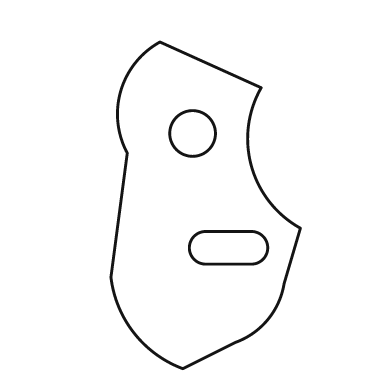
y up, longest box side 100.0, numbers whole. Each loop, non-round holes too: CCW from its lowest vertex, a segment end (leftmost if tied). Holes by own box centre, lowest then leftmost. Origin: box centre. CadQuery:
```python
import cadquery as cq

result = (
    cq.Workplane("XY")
    .moveTo(-7.0, -50.0)
    .lineTo(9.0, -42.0)
    .threePointArc((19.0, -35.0), (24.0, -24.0))
    .lineTo(29.0, -7.0)
    .threePointArc((14.0, 12.0), (17.0, 36.0))
    .lineTo(-14.0, 50.0)
    .threePointArc((-26.0, 35.0), (-24.0, 16.0))
    .lineTo(-29.0, -22.0)
    .threePointArc((-22.0, -39.0), (-7.0, -50.0))
    .close()
    .moveTo(0.0, -18.0)
    .lineTo(14.0, -18.0)
    .threePointArc((19.0, -13.0), (14.0, -8.0))
    .lineTo(0.0, -8.0)
    .threePointArc((-5.0, -13.0), (0.0, -18.0))
    .close()
    .moveTo(-4.0, 22.0)
    .circle(7.0)
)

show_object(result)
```